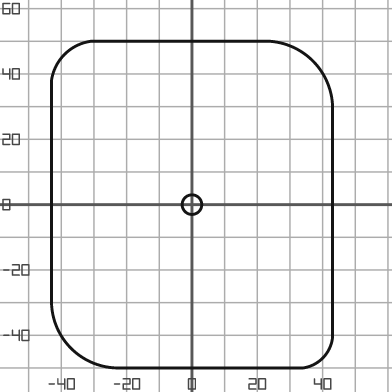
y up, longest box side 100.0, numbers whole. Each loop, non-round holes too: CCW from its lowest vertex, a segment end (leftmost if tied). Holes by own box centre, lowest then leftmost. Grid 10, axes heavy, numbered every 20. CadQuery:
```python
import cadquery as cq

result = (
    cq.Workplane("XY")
    .moveTo(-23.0, -50.0)
    .lineTo(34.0, -50.0)
    .threePointArc((40.0, -47.0), (43.0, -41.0))
    .lineTo(43.0, 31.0)
    .threePointArc((37.0, 44.0), (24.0, 50.0))
    .lineTo(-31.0, 50.0)
    .threePointArc((-39.0, 46.0), (-43.0, 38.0))
    .lineTo(-43.0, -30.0)
    .threePointArc((-37.0, -44.0), (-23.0, -50.0))
    .close()
    .moveTo(0.0, 0.0)
    .circle(3.0)
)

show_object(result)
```